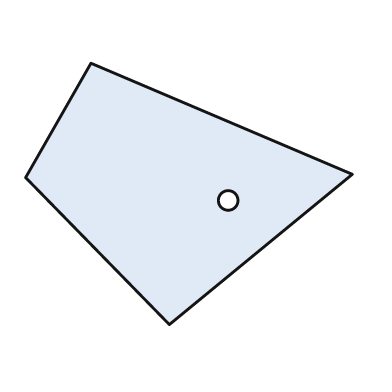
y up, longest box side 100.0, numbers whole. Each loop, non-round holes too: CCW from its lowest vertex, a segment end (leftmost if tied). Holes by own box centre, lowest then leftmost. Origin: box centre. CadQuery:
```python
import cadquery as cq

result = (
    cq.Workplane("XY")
    .moveTo(-6.0, -40.0)
    .lineTo(50.0, 6.0)
    .lineTo(-30.0, 40.0)
    .lineTo(-50.0, 5.0)
    .close()
    .moveTo(12.0, -2.0)
    .circle(3.0)
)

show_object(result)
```